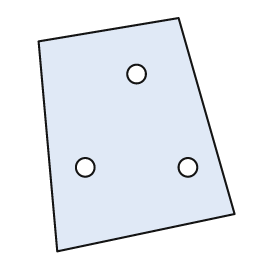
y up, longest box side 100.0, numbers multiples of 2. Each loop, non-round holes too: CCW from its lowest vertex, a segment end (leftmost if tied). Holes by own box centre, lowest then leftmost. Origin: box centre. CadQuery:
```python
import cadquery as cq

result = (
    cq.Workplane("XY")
    .moveTo(-34.0, -50.0)
    .lineTo(42.0, -34.0)
    .lineTo(18.0, 50.0)
    .lineTo(-42.0, 40.0)
    .close()
    .moveTo(-22.0, -14.0)
    .circle(4.0)
    .moveTo(22.0, -14.0)
    .circle(4.0)
    .moveTo(0.0, 26.0)
    .circle(4.0)
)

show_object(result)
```